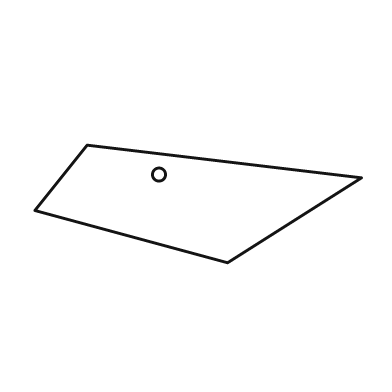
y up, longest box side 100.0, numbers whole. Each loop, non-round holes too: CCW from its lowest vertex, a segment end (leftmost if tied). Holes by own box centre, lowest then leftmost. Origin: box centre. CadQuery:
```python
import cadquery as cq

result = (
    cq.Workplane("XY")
    .moveTo(9.0, -18.0)
    .lineTo(50.0, 8.0)
    .lineTo(-34.0, 18.0)
    .lineTo(-50.0, -2.0)
    .close()
    .moveTo(-12.0, 9.0)
    .circle(2.0)
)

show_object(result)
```